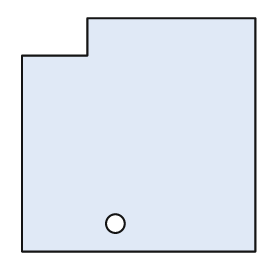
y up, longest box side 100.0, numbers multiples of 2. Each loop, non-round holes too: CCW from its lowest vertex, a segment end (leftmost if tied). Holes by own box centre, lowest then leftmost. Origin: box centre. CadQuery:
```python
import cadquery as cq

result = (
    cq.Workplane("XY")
    .moveTo(-50.0, -50.0)
    .lineTo(50.0, -50.0)
    .lineTo(50.0, 50.0)
    .lineTo(-22.0, 50.0)
    .lineTo(-22.0, 34.0)
    .lineTo(-50.0, 34.0)
    .close()
    .moveTo(-10.0, -38.0)
    .circle(4.0)
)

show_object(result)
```